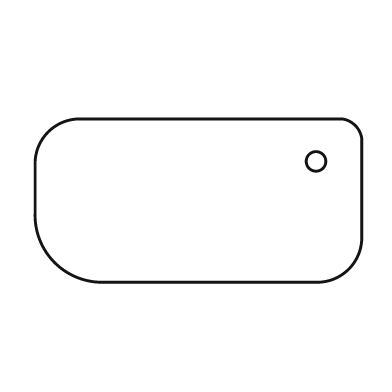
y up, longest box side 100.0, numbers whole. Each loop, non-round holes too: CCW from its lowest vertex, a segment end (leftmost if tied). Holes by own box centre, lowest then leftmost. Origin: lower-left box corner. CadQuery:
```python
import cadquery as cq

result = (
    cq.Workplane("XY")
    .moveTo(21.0, 0.0)
    .lineTo(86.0, 0.0)
    .threePointArc((96.0, 4.0), (100.0, 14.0))
    .lineTo(100.0, 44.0)
    .threePointArc((98.0, 48.0), (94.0, 50.0))
    .lineTo(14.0, 50.0)
    .threePointArc((4.0, 46.0), (0.0, 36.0))
    .lineTo(0.0, 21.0)
    .threePointArc((6.0, 6.0), (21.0, 0.0))
    .close()
    .moveTo(86.0, 37.0)
    .circle(3.0)
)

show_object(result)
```